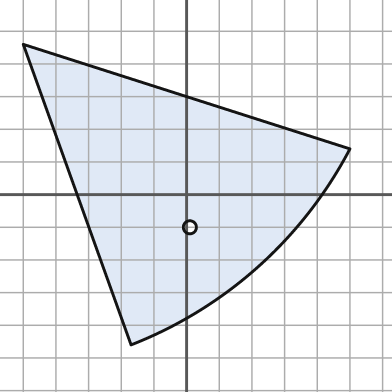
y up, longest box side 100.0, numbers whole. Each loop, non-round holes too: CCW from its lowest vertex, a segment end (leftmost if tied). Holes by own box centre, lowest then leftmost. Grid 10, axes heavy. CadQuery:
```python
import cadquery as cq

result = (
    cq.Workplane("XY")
    .moveTo(-17.0, -46.0)
    .threePointArc((22.0, -22.0), (50.0, 14.0))
    .lineTo(-50.0, 46.0)
    .close()
    .moveTo(1.0, -10.0)
    .circle(2.0)
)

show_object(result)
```